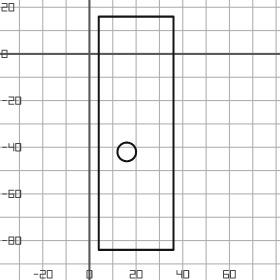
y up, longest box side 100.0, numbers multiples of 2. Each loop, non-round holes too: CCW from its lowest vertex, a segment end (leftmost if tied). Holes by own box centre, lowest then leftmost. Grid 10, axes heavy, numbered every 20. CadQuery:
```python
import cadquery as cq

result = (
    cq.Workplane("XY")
    .moveTo(4.0, -84.0)
    .lineTo(36.0, -84.0)
    .lineTo(36.0, 16.0)
    .lineTo(4.0, 16.0)
    .close()
    .moveTo(16.0, -42.0)
    .circle(4.0)
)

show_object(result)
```